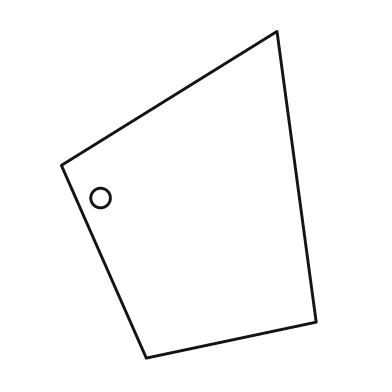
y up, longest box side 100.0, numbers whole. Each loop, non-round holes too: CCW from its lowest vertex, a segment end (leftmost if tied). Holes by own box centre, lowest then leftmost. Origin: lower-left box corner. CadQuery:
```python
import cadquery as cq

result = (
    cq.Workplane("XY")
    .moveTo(26.0, 0.0)
    .lineTo(78.0, 11.0)
    .lineTo(66.0, 100.0)
    .lineTo(0.0, 59.0)
    .close()
    .moveTo(12.0, 49.0)
    .circle(3.0)
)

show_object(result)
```